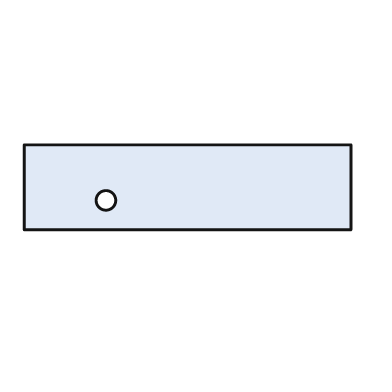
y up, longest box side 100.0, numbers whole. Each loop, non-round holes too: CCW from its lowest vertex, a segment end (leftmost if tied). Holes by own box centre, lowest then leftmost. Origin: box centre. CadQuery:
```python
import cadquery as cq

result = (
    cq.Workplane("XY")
    .moveTo(-50.0, -13.0)
    .lineTo(50.0, -13.0)
    .lineTo(50.0, 13.0)
    .lineTo(-50.0, 13.0)
    .close()
    .moveTo(-25.0, -4.0)
    .circle(3.0)
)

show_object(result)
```